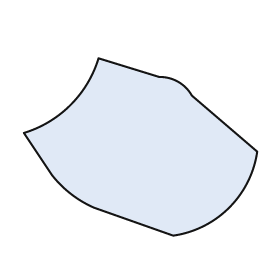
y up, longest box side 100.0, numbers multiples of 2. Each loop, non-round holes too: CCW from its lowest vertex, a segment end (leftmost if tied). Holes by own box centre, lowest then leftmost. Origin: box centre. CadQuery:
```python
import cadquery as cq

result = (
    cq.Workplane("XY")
    .moveTo(14.0, -38.0)
    .threePointArc((38.0, -26.0), (50.0, -2.0))
    .lineTo(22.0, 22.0)
    .threePointArc((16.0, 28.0), (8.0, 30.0))
    .lineTo(-18.0, 38.0)
    .threePointArc((-30.0, 18.0), (-50.0, 6.0))
    .lineTo(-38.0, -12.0)
    .threePointArc((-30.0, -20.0), (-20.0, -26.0))
    .close()
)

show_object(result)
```